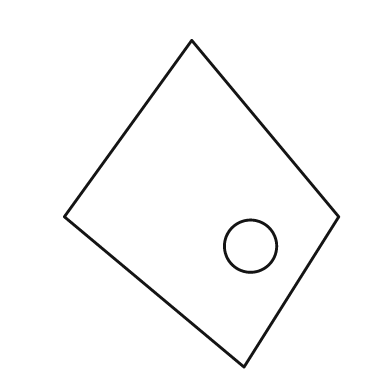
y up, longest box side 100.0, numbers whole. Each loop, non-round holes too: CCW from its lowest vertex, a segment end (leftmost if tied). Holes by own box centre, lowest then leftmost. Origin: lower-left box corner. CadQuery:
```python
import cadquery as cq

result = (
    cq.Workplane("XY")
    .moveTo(55.0, 0.0)
    .lineTo(84.0, 46.0)
    .lineTo(39.0, 100.0)
    .lineTo(0.0, 46.0)
    .close()
    .moveTo(57.0, 37.0)
    .circle(8.0)
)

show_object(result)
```